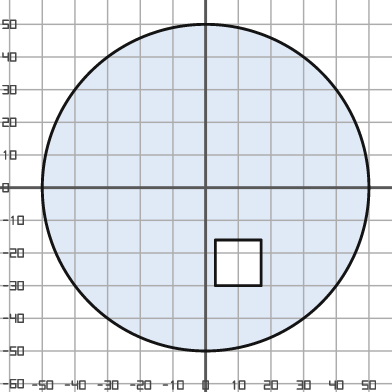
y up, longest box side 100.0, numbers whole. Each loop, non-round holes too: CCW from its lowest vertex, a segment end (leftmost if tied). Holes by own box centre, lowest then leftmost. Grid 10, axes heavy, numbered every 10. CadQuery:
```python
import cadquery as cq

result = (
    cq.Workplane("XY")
    .moveTo(0.0, 0.0)
    .circle(50.0)
    .moveTo(3.0, -30.0)
    .lineTo(17.0, -30.0)
    .lineTo(17.0, -16.0)
    .lineTo(3.0, -16.0)
    .close()
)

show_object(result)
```